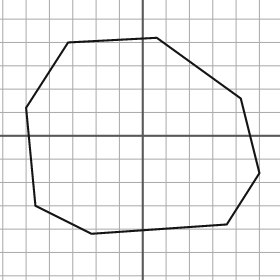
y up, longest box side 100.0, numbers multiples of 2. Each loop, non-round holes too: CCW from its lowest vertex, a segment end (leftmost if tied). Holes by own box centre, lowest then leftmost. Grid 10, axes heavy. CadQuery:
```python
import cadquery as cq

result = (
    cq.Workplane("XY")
    .moveTo(-22.0, -42.0)
    .lineTo(36.0, -38.0)
    .lineTo(50.0, -16.0)
    .lineTo(42.0, 16.0)
    .lineTo(6.0, 42.0)
    .lineTo(-32.0, 40.0)
    .lineTo(-50.0, 12.0)
    .lineTo(-46.0, -30.0)
    .close()
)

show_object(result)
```